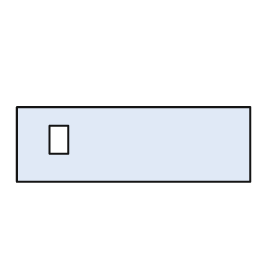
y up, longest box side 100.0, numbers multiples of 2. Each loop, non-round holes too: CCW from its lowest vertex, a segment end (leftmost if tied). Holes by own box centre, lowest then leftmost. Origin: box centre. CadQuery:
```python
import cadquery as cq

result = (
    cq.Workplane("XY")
    .moveTo(-50.0, -16.0)
    .lineTo(50.0, -16.0)
    .lineTo(50.0, 16.0)
    .lineTo(-50.0, 16.0)
    .close()
    .moveTo(-36.0, -4.0)
    .lineTo(-28.0, -4.0)
    .lineTo(-28.0, 8.0)
    .lineTo(-36.0, 8.0)
    .close()
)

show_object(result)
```